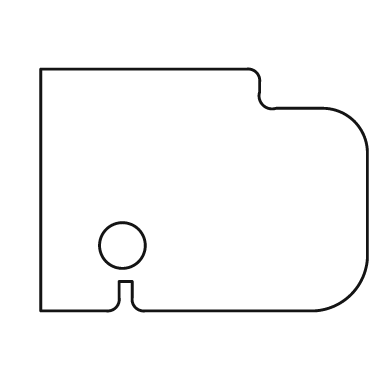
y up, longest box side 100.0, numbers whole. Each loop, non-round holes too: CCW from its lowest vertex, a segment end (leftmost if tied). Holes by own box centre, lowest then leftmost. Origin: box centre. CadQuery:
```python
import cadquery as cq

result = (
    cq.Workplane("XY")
    .moveTo(-50.0, -37.0)
    .lineTo(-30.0, -37.0)
    .threePointArc((-27.0, -36.0), (-26.0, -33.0))
    .lineTo(-26.0, -28.0)
    .lineTo(-22.0, -28.0)
    .lineTo(-22.0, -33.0)
    .threePointArc((-21.0, -36.0), (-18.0, -37.0))
    .lineTo(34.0, -37.0)
    .threePointArc((45.0, -32.0), (50.0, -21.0))
    .lineTo(50.0, 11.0)
    .threePointArc((46.0, 21.0), (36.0, 25.0))
    .lineTo(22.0, 25.0)
    .threePointArc((18.0, 26.0), (17.0, 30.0))
    .lineTo(17.0, 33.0)
    .threePointArc((16.0, 36.0), (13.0, 37.0))
    .lineTo(-50.0, 37.0)
    .close()
    .moveTo(-25.0, -17.0)
    .circle(7.0)
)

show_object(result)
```